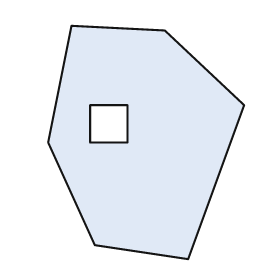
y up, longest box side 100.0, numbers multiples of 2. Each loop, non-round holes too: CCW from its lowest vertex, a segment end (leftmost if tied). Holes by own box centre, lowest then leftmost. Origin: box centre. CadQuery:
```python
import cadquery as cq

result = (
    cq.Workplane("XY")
    .moveTo(18.0, -50.0)
    .lineTo(42.0, 16.0)
    .lineTo(8.0, 48.0)
    .lineTo(-32.0, 50.0)
    .lineTo(-42.0, 0.0)
    .lineTo(-22.0, -44.0)
    .close()
    .moveTo(-24.0, 0.0)
    .lineTo(-8.0, 0.0)
    .lineTo(-8.0, 16.0)
    .lineTo(-24.0, 16.0)
    .close()
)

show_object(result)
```